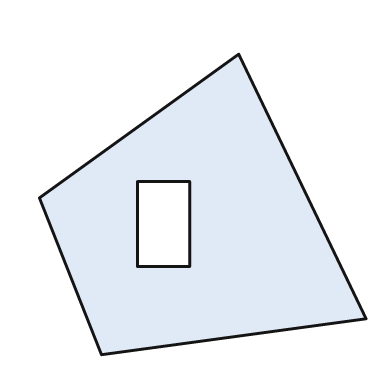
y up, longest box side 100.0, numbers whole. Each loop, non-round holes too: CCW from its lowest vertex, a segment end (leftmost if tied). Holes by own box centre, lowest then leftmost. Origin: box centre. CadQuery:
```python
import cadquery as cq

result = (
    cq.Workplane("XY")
    .moveTo(-31.0, -46.0)
    .lineTo(50.0, -35.0)
    .lineTo(11.0, 46.0)
    .lineTo(-50.0, 2.0)
    .close()
    .moveTo(-20.0, -19.0)
    .lineTo(-4.0, -19.0)
    .lineTo(-4.0, 7.0)
    .lineTo(-20.0, 7.0)
    .close()
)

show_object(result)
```